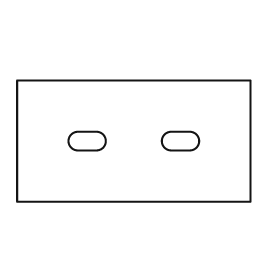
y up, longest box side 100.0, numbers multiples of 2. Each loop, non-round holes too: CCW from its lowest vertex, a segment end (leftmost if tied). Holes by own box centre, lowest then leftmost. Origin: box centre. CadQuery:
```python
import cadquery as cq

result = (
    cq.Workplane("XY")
    .moveTo(-50.0, -26.0)
    .lineTo(50.0, -26.0)
    .lineTo(50.0, 26.0)
    .lineTo(-50.0, 26.0)
    .close()
    .moveTo(-24.0, -4.0)
    .lineTo(-16.0, -4.0)
    .threePointArc((-12.0, 0.0), (-16.0, 4.0))
    .lineTo(-24.0, 4.0)
    .threePointArc((-28.0, 0.0), (-24.0, -4.0))
    .close()
    .moveTo(16.0, -4.0)
    .lineTo(24.0, -4.0)
    .threePointArc((28.0, 0.0), (24.0, 4.0))
    .lineTo(16.0, 4.0)
    .threePointArc((12.0, 0.0), (16.0, -4.0))
    .close()
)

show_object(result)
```